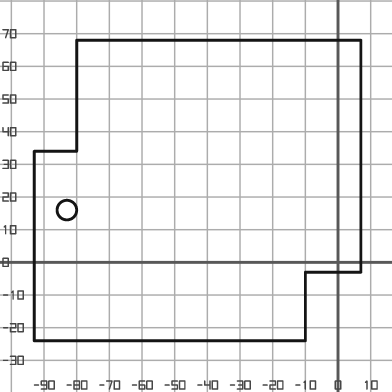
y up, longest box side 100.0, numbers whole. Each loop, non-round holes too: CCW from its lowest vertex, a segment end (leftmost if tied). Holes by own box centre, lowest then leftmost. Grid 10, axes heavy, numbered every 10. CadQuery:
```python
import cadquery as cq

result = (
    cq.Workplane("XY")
    .moveTo(-93.0, -24.0)
    .lineTo(-10.0, -24.0)
    .lineTo(-10.0, -3.0)
    .lineTo(7.0, -3.0)
    .lineTo(7.0, 68.0)
    .lineTo(-80.0, 68.0)
    .lineTo(-80.0, 34.0)
    .lineTo(-93.0, 34.0)
    .close()
    .moveTo(-83.0, 16.0)
    .circle(3.0)
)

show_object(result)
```